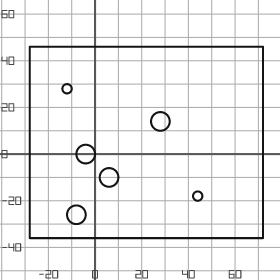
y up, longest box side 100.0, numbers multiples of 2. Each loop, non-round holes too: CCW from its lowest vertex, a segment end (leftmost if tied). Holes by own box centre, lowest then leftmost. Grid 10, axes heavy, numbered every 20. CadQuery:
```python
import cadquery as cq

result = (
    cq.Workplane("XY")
    .moveTo(-28.0, -36.0)
    .lineTo(72.0, -36.0)
    .lineTo(72.0, 46.0)
    .lineTo(-28.0, 46.0)
    .close()
    .moveTo(-8.0, -26.0)
    .circle(4.0)
    .moveTo(44.0, -18.0)
    .circle(2.0)
    .moveTo(6.0, -10.0)
    .circle(4.0)
    .moveTo(-4.0, 0.0)
    .circle(4.0)
    .moveTo(28.0, 14.0)
    .circle(4.0)
    .moveTo(-12.0, 28.0)
    .circle(2.0)
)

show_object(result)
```